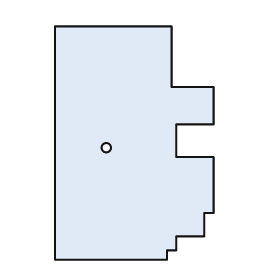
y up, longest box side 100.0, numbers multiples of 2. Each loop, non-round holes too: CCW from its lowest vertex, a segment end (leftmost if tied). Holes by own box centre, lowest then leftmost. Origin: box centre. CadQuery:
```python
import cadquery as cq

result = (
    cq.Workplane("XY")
    .moveTo(-34.0, -50.0)
    .lineTo(14.0, -50.0)
    .lineTo(14.0, -46.0)
    .lineTo(18.0, -46.0)
    .lineTo(18.0, -40.0)
    .lineTo(30.0, -40.0)
    .lineTo(30.0, -30.0)
    .lineTo(34.0, -30.0)
    .lineTo(34.0, -6.0)
    .lineTo(18.0, -6.0)
    .lineTo(18.0, 8.0)
    .lineTo(34.0, 8.0)
    .lineTo(34.0, 24.0)
    .lineTo(16.0, 24.0)
    .lineTo(16.0, 50.0)
    .lineTo(-34.0, 50.0)
    .close()
    .moveTo(-12.0, -2.0)
    .circle(2.0)
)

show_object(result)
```